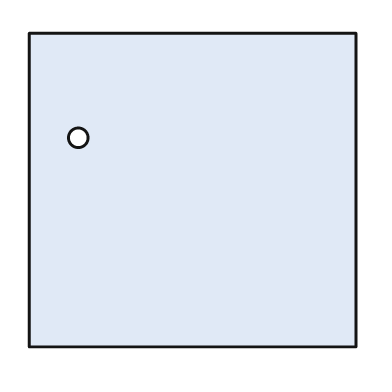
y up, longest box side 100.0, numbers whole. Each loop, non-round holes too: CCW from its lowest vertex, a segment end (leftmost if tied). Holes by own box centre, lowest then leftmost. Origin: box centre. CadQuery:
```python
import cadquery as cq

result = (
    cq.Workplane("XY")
    .moveTo(-50.0, -48.0)
    .lineTo(50.0, -48.0)
    .lineTo(50.0, 48.0)
    .lineTo(-50.0, 48.0)
    .close()
    .moveTo(-35.0, 16.0)
    .circle(3.0)
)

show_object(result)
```